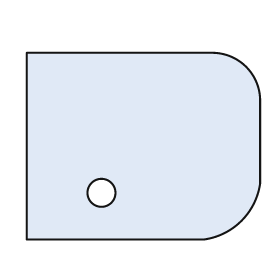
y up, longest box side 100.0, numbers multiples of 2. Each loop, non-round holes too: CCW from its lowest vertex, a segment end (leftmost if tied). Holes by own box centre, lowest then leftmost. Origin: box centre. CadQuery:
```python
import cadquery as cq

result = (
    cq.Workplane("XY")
    .moveTo(-50.0, -40.0)
    .lineTo(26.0, -40.0)
    .threePointArc((42.0, -32.0), (50.0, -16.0))
    .lineTo(50.0, 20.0)
    .threePointArc((44.0, 34.0), (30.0, 40.0))
    .lineTo(-50.0, 40.0)
    .close()
    .moveTo(-18.0, -20.0)
    .circle(6.0)
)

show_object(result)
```